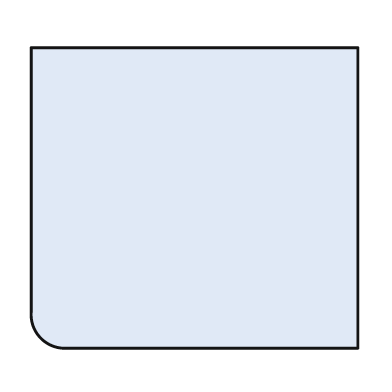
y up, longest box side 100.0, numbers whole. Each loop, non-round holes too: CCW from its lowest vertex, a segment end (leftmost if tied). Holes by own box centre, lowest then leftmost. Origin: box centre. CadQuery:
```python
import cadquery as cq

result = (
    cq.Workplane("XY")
    .moveTo(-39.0, -46.0)
    .lineTo(50.0, -46.0)
    .lineTo(50.0, 46.0)
    .lineTo(-50.0, 46.0)
    .lineTo(-50.0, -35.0)
    .threePointArc((-47.0, -43.0), (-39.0, -46.0))
    .close()
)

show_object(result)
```